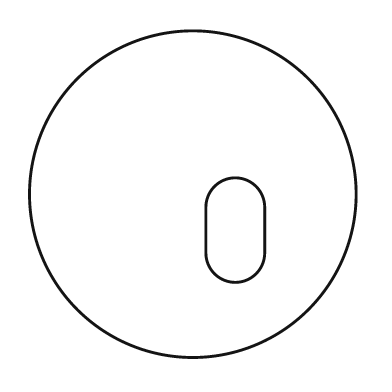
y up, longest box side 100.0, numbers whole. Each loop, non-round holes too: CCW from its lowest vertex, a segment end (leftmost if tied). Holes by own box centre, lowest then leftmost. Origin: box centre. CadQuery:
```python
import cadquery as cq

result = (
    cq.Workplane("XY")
    .moveTo(0.0, 0.0)
    .circle(50.0)
    .moveTo(4.0, -18.0)
    .threePointArc((13.0, -27.0), (22.0, -18.0))
    .lineTo(22.0, -4.0)
    .threePointArc((13.0, 5.0), (4.0, -4.0))
    .close()
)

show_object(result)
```